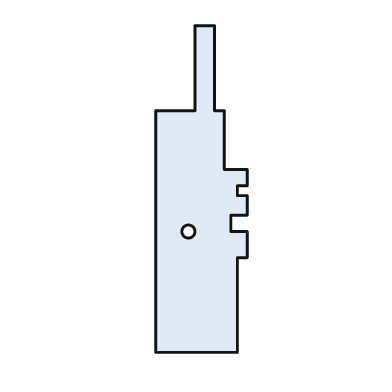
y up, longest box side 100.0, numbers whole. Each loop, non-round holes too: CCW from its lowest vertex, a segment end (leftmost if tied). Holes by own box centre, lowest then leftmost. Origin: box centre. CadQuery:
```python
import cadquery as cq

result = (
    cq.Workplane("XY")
    .moveTo(-14.0, -50.0)
    .lineTo(11.0, -50.0)
    .lineTo(11.0, -21.0)
    .lineTo(14.0, -21.0)
    .lineTo(14.0, -13.0)
    .lineTo(9.0, -13.0)
    .lineTo(9.0, -8.0)
    .lineTo(14.0, -8.0)
    .lineTo(14.0, -2.0)
    .lineTo(11.0, -2.0)
    .lineTo(11.0, 1.0)
    .lineTo(14.0, 1.0)
    .lineTo(14.0, 6.0)
    .lineTo(7.0, 6.0)
    .lineTo(7.0, 24.0)
    .lineTo(4.0, 24.0)
    .lineTo(4.0, 50.0)
    .lineTo(-2.0, 50.0)
    .lineTo(-2.0, 24.0)
    .lineTo(-14.0, 24.0)
    .close()
    .moveTo(-4.0, -13.0)
    .circle(2.0)
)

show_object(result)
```